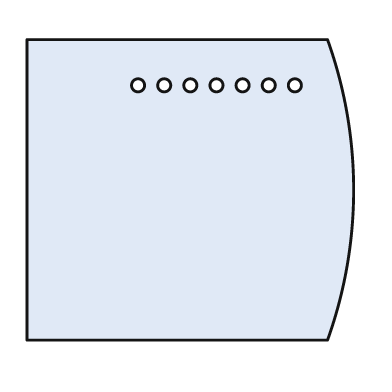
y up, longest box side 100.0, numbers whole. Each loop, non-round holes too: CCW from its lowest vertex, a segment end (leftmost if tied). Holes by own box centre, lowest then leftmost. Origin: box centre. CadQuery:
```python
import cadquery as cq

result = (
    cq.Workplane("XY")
    .moveTo(-50.0, -46.0)
    .lineTo(42.0, -46.0)
    .threePointArc((50.0, 0.0), (42.0, 46.0))
    .lineTo(-50.0, 46.0)
    .close()
    .moveTo(-16.0, 32.0)
    .circle(2.0)
    .moveTo(-8.0, 32.0)
    .circle(2.0)
    .moveTo(0.0, 32.0)
    .circle(2.0)
    .moveTo(8.0, 32.0)
    .circle(2.0)
    .moveTo(16.0, 32.0)
    .circle(2.0)
    .moveTo(24.0, 32.0)
    .circle(2.0)
    .moveTo(32.0, 32.0)
    .circle(2.0)
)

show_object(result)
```